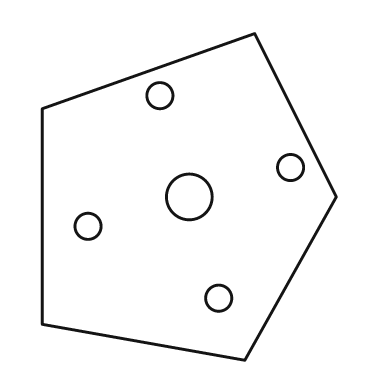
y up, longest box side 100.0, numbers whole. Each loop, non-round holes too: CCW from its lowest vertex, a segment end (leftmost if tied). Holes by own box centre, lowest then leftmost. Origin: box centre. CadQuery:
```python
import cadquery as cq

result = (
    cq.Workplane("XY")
    .moveTo(17.0, -50.0)
    .lineTo(45.0, 0.0)
    .lineTo(20.0, 50.0)
    .lineTo(-45.0, 27.0)
    .lineTo(-45.0, -39.0)
    .close()
    .moveTo(9.0, -31.0)
    .circle(4.0)
    .moveTo(-31.0, -9.0)
    .circle(4.0)
    .moveTo(0.0, 0.0)
    .circle(7.0)
    .moveTo(31.0, 9.0)
    .circle(4.0)
    .moveTo(-9.0, 31.0)
    .circle(4.0)
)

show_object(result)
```